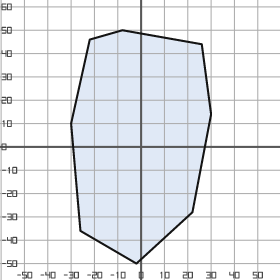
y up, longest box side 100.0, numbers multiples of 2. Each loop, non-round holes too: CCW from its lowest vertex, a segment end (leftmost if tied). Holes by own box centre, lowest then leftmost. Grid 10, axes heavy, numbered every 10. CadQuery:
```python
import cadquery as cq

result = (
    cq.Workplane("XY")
    .moveTo(-2.0, -50.0)
    .lineTo(22.0, -28.0)
    .lineTo(30.0, 14.0)
    .lineTo(26.0, 44.0)
    .lineTo(-8.0, 50.0)
    .lineTo(-22.0, 46.0)
    .lineTo(-30.0, 10.0)
    .lineTo(-26.0, -36.0)
    .close()
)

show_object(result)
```